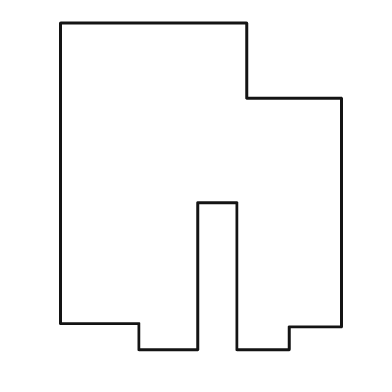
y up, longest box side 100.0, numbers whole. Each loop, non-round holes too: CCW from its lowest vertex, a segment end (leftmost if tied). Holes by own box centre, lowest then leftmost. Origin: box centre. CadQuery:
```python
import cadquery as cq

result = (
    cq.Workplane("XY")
    .moveTo(-19.0, -50.0)
    .lineTo(-1.0, -50.0)
    .lineTo(-1.0, -5.0)
    .lineTo(11.0, -5.0)
    .lineTo(11.0, -50.0)
    .lineTo(27.0, -50.0)
    .lineTo(27.0, -43.0)
    .lineTo(43.0, -43.0)
    .lineTo(43.0, 27.0)
    .lineTo(14.0, 27.0)
    .lineTo(14.0, 50.0)
    .lineTo(-43.0, 50.0)
    .lineTo(-43.0, -42.0)
    .lineTo(-19.0, -42.0)
    .close()
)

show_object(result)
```